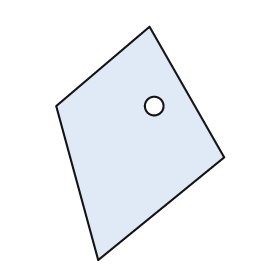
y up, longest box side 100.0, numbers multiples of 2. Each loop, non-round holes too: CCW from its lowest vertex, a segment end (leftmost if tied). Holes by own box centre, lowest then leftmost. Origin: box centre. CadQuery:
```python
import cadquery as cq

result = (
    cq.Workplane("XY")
    .moveTo(-18.0, -50.0)
    .lineTo(36.0, -6.0)
    .lineTo(4.0, 50.0)
    .lineTo(-36.0, 16.0)
    .close()
    .moveTo(6.0, 16.0)
    .circle(4.0)
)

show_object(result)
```